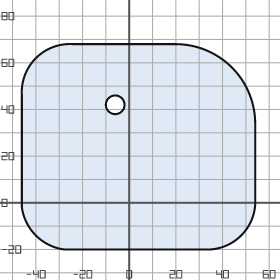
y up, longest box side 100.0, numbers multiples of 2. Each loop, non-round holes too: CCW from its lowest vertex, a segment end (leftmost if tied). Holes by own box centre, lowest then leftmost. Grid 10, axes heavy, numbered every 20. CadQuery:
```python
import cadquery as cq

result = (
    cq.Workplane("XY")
    .moveTo(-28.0, -20.0)
    .lineTo(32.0, -20.0)
    .threePointArc((48.0, -14.0), (54.0, 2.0))
    .lineTo(54.0, 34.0)
    .threePointArc((44.0, 58.0), (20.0, 68.0))
    .lineTo(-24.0, 68.0)
    .threePointArc((-40.0, 62.0), (-46.0, 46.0))
    .lineTo(-46.0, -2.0)
    .threePointArc((-40.0, -14.0), (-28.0, -20.0))
    .close()
    .moveTo(-6.0, 42.0)
    .circle(4.0)
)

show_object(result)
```